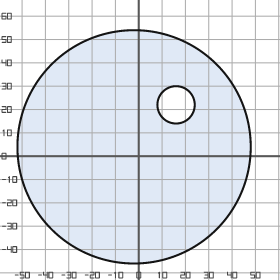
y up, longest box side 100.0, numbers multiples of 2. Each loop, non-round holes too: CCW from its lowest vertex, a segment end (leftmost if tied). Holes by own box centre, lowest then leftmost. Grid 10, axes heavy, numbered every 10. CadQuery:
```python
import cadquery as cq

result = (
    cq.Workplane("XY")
    .moveTo(-2.0, 4.0)
    .circle(50.0)
    .moveTo(16.0, 22.0)
    .circle(8.0)
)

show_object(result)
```